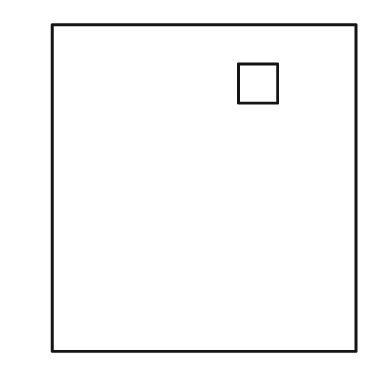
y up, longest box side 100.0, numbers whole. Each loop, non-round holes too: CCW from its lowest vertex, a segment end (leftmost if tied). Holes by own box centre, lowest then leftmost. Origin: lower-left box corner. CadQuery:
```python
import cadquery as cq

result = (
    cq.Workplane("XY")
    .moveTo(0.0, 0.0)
    .lineTo(93.0, 0.0)
    .lineTo(93.0, 100.0)
    .lineTo(0.0, 100.0)
    .close()
    .moveTo(57.0, 76.0)
    .lineTo(69.0, 76.0)
    .lineTo(69.0, 88.0)
    .lineTo(57.0, 88.0)
    .close()
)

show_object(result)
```